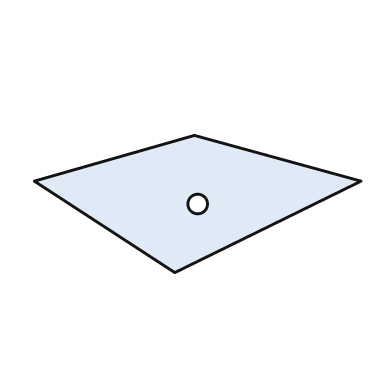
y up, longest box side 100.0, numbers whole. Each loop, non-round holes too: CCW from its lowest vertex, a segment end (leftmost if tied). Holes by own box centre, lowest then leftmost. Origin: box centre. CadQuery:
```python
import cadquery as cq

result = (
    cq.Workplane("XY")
    .moveTo(-7.0, -21.0)
    .lineTo(50.0, 7.0)
    .lineTo(-1.0, 21.0)
    .lineTo(-50.0, 7.0)
    .close()
    .moveTo(0.0, 0.0)
    .circle(3.0)
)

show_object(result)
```